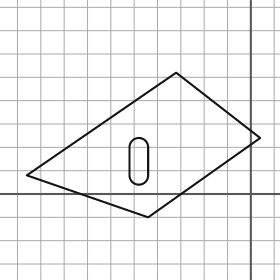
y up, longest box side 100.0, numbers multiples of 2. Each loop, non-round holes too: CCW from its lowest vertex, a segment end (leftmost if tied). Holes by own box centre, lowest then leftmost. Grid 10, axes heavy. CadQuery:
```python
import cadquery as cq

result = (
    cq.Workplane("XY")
    .moveTo(-44.0, -10.0)
    .lineTo(4.0, 24.0)
    .lineTo(-32.0, 52.0)
    .lineTo(-96.0, 8.0)
    .close()
    .moveTo(-52.0, 8.0)
    .threePointArc((-48.0, 4.0), (-44.0, 8.0))
    .lineTo(-44.0, 20.0)
    .threePointArc((-48.0, 24.0), (-52.0, 20.0))
    .close()
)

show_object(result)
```